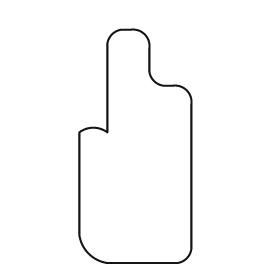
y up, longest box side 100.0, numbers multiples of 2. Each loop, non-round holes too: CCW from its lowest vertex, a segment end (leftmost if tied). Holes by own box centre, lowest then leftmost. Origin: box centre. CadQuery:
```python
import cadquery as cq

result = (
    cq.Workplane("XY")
    .moveTo(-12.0, -50.0)
    .lineTo(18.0, -50.0)
    .threePointArc((22.0, -48.0), (24.0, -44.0))
    .lineTo(24.0, 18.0)
    .threePointArc((22.0, 24.0), (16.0, 26.0))
    .lineTo(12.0, 26.0)
    .threePointArc((8.0, 28.0), (6.0, 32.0))
    .lineTo(6.0, 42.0)
    .threePointArc((4.0, 48.0), (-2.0, 50.0))
    .lineTo(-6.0, 50.0)
    .threePointArc((-10.0, 48.0), (-12.0, 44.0))
    .lineTo(-12.0, 6.0)
    .threePointArc((-18.0, 8.0), (-24.0, 6.0))
    .lineTo(-24.0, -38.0)
    .threePointArc((-20.0, -46.0), (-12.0, -50.0))
    .close()
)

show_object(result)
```